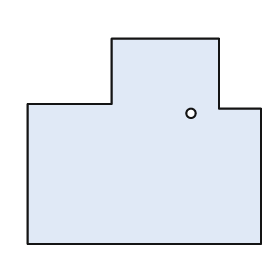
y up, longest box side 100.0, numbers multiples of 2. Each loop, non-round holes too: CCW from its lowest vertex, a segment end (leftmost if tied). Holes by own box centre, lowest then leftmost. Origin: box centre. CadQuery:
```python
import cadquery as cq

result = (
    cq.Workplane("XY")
    .moveTo(-50.0, -44.0)
    .lineTo(50.0, -44.0)
    .lineTo(50.0, 14.0)
    .lineTo(32.0, 14.0)
    .lineTo(32.0, 44.0)
    .lineTo(-14.0, 44.0)
    .lineTo(-14.0, 16.0)
    .lineTo(-50.0, 16.0)
    .close()
    .moveTo(20.0, 12.0)
    .circle(2.0)
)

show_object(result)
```